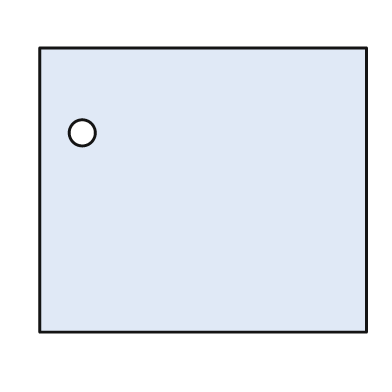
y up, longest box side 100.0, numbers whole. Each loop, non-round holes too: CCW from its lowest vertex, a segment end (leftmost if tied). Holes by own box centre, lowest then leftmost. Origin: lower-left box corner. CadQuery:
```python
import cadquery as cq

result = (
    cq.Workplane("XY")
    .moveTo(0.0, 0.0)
    .lineTo(100.0, 0.0)
    .lineTo(100.0, 87.0)
    .lineTo(0.0, 87.0)
    .close()
    .moveTo(13.0, 61.0)
    .circle(4.0)
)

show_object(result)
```